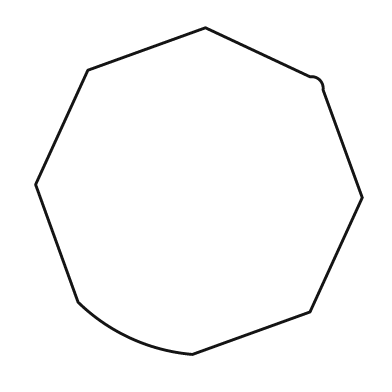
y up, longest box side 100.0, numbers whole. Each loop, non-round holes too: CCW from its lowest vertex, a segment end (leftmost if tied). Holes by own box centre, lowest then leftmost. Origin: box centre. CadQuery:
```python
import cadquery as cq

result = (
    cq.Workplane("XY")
    .moveTo(-2.0, -50.0)
    .lineTo(34.0, -37.0)
    .lineTo(50.0, -2.0)
    .lineTo(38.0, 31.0)
    .threePointArc((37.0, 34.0), (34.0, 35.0))
    .lineTo(2.0, 50.0)
    .lineTo(-34.0, 37.0)
    .lineTo(-50.0, 2.0)
    .lineTo(-37.0, -34.0)
    .threePointArc((-21.0, -45.0), (-2.0, -50.0))
    .close()
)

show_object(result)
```